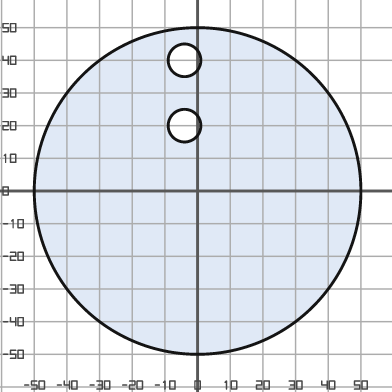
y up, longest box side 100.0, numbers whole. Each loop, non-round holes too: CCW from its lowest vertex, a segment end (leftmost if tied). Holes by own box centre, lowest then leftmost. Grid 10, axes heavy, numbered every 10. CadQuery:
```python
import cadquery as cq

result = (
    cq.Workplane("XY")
    .moveTo(0.0, 0.0)
    .circle(50.0)
    .moveTo(-4.0, 20.0)
    .circle(5.0)
    .moveTo(-4.0, 40.0)
    .circle(5.0)
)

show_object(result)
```